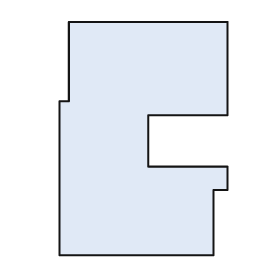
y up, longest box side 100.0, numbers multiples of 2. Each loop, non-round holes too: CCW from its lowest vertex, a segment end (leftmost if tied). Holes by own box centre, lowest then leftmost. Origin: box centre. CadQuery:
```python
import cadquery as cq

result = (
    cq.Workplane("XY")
    .moveTo(-36.0, -50.0)
    .lineTo(30.0, -50.0)
    .lineTo(30.0, -22.0)
    .lineTo(36.0, -22.0)
    .lineTo(36.0, -12.0)
    .lineTo(2.0, -12.0)
    .lineTo(2.0, 10.0)
    .lineTo(36.0, 10.0)
    .lineTo(36.0, 50.0)
    .lineTo(-32.0, 50.0)
    .lineTo(-32.0, 16.0)
    .lineTo(-36.0, 16.0)
    .close()
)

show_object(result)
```